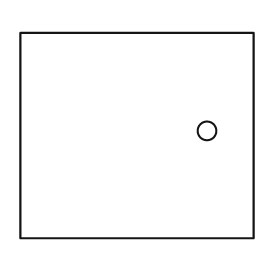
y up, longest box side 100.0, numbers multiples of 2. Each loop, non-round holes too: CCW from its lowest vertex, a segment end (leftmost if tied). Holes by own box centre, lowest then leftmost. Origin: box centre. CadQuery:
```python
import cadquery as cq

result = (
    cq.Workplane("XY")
    .moveTo(-50.0, -44.0)
    .lineTo(50.0, -44.0)
    .lineTo(50.0, 44.0)
    .lineTo(-50.0, 44.0)
    .close()
    .moveTo(30.0, 2.0)
    .circle(4.0)
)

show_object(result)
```